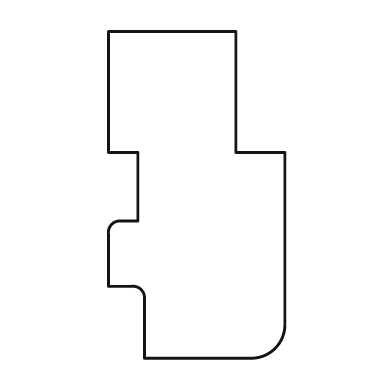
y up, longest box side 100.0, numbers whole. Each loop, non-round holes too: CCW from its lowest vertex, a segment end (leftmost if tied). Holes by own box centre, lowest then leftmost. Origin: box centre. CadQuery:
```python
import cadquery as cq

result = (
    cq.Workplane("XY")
    .moveTo(-16.0, -50.0)
    .lineTo(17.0, -50.0)
    .threePointArc((24.0, -47.0), (27.0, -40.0))
    .lineTo(27.0, 13.0)
    .lineTo(12.0, 13.0)
    .lineTo(12.0, 50.0)
    .lineTo(-27.0, 50.0)
    .lineTo(-27.0, 13.0)
    .lineTo(-18.0, 13.0)
    .lineTo(-18.0, -8.0)
    .lineTo(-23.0, -8.0)
    .threePointArc((-26.0, -9.0), (-27.0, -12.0))
    .lineTo(-27.0, -28.0)
    .lineTo(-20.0, -28.0)
    .threePointArc((-17.0, -29.0), (-16.0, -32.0))
    .close()
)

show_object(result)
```